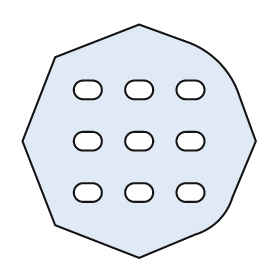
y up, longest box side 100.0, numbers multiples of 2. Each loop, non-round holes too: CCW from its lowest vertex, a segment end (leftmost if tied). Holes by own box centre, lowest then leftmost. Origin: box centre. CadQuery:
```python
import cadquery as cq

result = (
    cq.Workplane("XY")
    .moveTo(0.0, -50.0)
    .lineTo(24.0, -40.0)
    .threePointArc((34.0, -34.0), (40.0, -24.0))
    .lineTo(50.0, 0.0)
    .lineTo(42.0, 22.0)
    .threePointArc((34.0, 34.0), (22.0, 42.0))
    .lineTo(0.0, 50.0)
    .lineTo(-36.0, 36.0)
    .lineTo(-50.0, 0.0)
    .lineTo(-36.0, -36.0)
    .close()
    .moveTo(-24.0, -26.0)
    .lineTo(-20.0, -26.0)
    .threePointArc((-16.0, -22.0), (-20.0, -18.0))
    .lineTo(-24.0, -18.0)
    .threePointArc((-28.0, -22.0), (-24.0, -26.0))
    .close()
    .moveTo(-2.0, -26.0)
    .lineTo(2.0, -26.0)
    .threePointArc((6.0, -22.0), (2.0, -18.0))
    .lineTo(-2.0, -18.0)
    .threePointArc((-6.0, -22.0), (-2.0, -26.0))
    .close()
    .moveTo(20.0, -26.0)
    .lineTo(24.0, -26.0)
    .threePointArc((28.0, -22.0), (24.0, -18.0))
    .lineTo(20.0, -18.0)
    .threePointArc((16.0, -22.0), (20.0, -26.0))
    .close()
    .moveTo(-24.0, -4.0)
    .lineTo(-20.0, -4.0)
    .threePointArc((-16.0, 0.0), (-20.0, 4.0))
    .lineTo(-24.0, 4.0)
    .threePointArc((-28.0, 0.0), (-24.0, -4.0))
    .close()
    .moveTo(-2.0, -4.0)
    .lineTo(2.0, -4.0)
    .threePointArc((6.0, 0.0), (2.0, 4.0))
    .lineTo(-2.0, 4.0)
    .threePointArc((-6.0, 0.0), (-2.0, -4.0))
    .close()
    .moveTo(20.0, -4.0)
    .lineTo(24.0, -4.0)
    .threePointArc((28.0, 0.0), (24.0, 4.0))
    .lineTo(20.0, 4.0)
    .threePointArc((16.0, 0.0), (20.0, -4.0))
    .close()
    .moveTo(-24.0, 18.0)
    .lineTo(-20.0, 18.0)
    .threePointArc((-16.0, 22.0), (-20.0, 26.0))
    .lineTo(-24.0, 26.0)
    .threePointArc((-28.0, 22.0), (-24.0, 18.0))
    .close()
    .moveTo(-2.0, 18.0)
    .lineTo(2.0, 18.0)
    .threePointArc((6.0, 22.0), (2.0, 26.0))
    .lineTo(-2.0, 26.0)
    .threePointArc((-6.0, 22.0), (-2.0, 18.0))
    .close()
    .moveTo(20.0, 18.0)
    .lineTo(24.0, 18.0)
    .threePointArc((28.0, 22.0), (24.0, 26.0))
    .lineTo(20.0, 26.0)
    .threePointArc((16.0, 22.0), (20.0, 18.0))
    .close()
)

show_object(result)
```